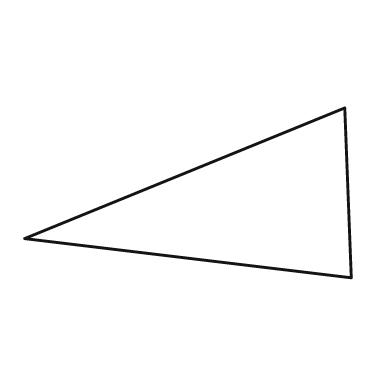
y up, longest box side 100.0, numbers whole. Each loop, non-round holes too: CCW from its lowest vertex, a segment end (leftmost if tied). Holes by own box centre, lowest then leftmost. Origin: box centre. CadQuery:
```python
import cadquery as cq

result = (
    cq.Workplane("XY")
    .moveTo(50.0, -26.0)
    .lineTo(48.0, 26.0)
    .lineTo(-50.0, -14.0)
    .close()
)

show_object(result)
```